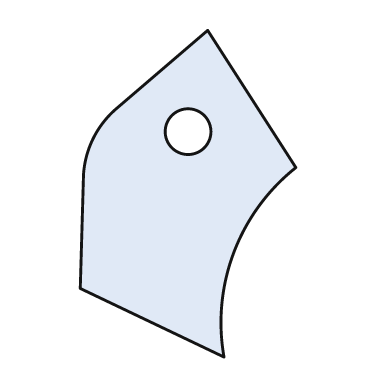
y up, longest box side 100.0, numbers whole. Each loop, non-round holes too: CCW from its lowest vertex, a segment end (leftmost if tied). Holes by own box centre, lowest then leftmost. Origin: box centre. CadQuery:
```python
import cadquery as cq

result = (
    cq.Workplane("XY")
    .moveTo(11.0, -50.0)
    .threePointArc((14.0, -18.0), (33.0, 8.0))
    .lineTo(6.0, 50.0)
    .lineTo(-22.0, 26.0)
    .threePointArc((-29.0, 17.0), (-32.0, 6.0))
    .lineTo(-33.0, -29.0)
    .close()
    .moveTo(0.0, 19.0)
    .circle(7.0)
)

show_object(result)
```